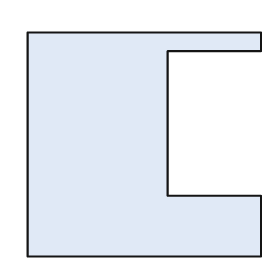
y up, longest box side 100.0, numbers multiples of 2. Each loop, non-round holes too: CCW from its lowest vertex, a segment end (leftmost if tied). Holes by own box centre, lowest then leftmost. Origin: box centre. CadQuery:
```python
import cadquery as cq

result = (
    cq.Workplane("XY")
    .moveTo(-50.0, -48.0)
    .lineTo(50.0, -48.0)
    .lineTo(50.0, -22.0)
    .lineTo(10.0, -22.0)
    .lineTo(10.0, 40.0)
    .lineTo(50.0, 40.0)
    .lineTo(50.0, 48.0)
    .lineTo(-50.0, 48.0)
    .close()
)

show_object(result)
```